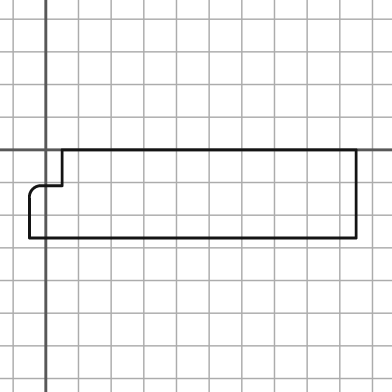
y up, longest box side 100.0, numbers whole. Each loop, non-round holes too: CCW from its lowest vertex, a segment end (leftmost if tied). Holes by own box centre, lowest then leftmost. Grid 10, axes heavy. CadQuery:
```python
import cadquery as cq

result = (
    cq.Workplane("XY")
    .moveTo(-5.0, -27.0)
    .lineTo(95.0, -27.0)
    .lineTo(95.0, 0.0)
    .lineTo(5.0, 0.0)
    .lineTo(5.0, -11.0)
    .lineTo(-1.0, -11.0)
    .threePointArc((-4.0, -12.0), (-5.0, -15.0))
    .close()
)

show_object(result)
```